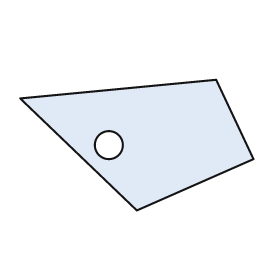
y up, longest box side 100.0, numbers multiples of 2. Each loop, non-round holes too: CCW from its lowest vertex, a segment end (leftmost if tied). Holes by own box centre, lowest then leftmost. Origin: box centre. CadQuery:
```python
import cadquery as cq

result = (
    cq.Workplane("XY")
    .moveTo(0.0, -28.0)
    .lineTo(50.0, -6.0)
    .lineTo(34.0, 28.0)
    .lineTo(-50.0, 20.0)
    .close()
    .moveTo(-12.0, 0.0)
    .circle(6.0)
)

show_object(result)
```